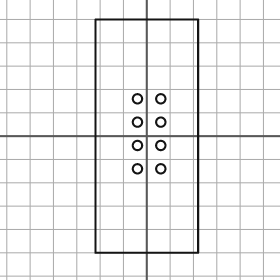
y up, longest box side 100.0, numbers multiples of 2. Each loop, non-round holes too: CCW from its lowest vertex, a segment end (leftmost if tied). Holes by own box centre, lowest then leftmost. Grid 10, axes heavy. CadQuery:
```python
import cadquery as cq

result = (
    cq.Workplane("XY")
    .moveTo(-22.0, -50.0)
    .lineTo(22.0, -50.0)
    .lineTo(22.0, 50.0)
    .lineTo(-22.0, 50.0)
    .close()
    .moveTo(-4.0, -14.0)
    .circle(2.0)
    .moveTo(6.0, -14.0)
    .circle(2.0)
    .moveTo(-4.0, -4.0)
    .circle(2.0)
    .moveTo(6.0, -4.0)
    .circle(2.0)
    .moveTo(-4.0, 6.0)
    .circle(2.0)
    .moveTo(6.0, 6.0)
    .circle(2.0)
    .moveTo(-4.0, 16.0)
    .circle(2.0)
    .moveTo(6.0, 16.0)
    .circle(2.0)
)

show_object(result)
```